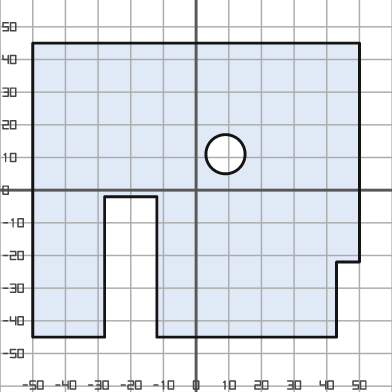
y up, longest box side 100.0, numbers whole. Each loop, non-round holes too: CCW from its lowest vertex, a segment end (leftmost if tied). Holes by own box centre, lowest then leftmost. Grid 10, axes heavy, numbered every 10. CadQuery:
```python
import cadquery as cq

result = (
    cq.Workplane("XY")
    .moveTo(-50.0, -45.0)
    .lineTo(-28.0, -45.0)
    .lineTo(-28.0, -2.0)
    .lineTo(-12.0, -2.0)
    .lineTo(-12.0, -45.0)
    .lineTo(43.0, -45.0)
    .lineTo(43.0, -22.0)
    .lineTo(50.0, -22.0)
    .lineTo(50.0, 45.0)
    .lineTo(-50.0, 45.0)
    .close()
    .moveTo(9.0, 11.0)
    .circle(6.0)
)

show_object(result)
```